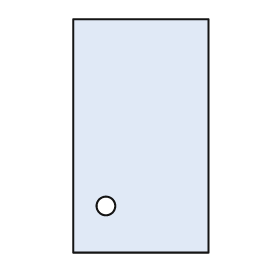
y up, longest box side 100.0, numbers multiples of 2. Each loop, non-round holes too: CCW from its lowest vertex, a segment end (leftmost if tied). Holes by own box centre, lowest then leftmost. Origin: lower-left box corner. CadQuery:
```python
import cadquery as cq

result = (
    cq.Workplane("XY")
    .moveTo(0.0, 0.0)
    .lineTo(58.0, 0.0)
    .lineTo(58.0, 100.0)
    .lineTo(0.0, 100.0)
    .close()
    .moveTo(14.0, 20.0)
    .circle(4.0)
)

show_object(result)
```